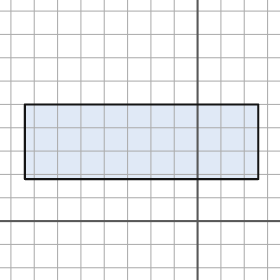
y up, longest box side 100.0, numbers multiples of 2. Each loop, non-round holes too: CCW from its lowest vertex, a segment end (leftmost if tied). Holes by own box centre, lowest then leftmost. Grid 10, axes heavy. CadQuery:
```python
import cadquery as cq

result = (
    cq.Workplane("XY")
    .moveTo(-74.0, 18.0)
    .lineTo(26.0, 18.0)
    .lineTo(26.0, 50.0)
    .lineTo(-74.0, 50.0)
    .close()
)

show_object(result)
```